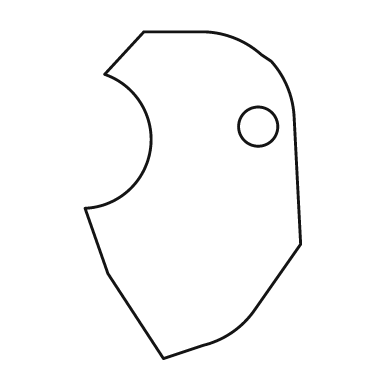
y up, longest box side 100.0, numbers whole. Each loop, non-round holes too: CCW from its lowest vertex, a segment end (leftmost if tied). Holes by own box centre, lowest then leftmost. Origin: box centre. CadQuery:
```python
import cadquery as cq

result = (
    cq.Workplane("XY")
    .moveTo(-9.0, -50.0)
    .lineTo(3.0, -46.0)
    .threePointArc((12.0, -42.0), (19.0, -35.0))
    .lineTo(33.0, -15.0)
    .lineTo(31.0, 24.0)
    .threePointArc((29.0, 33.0), (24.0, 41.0))
    .lineTo(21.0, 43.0)
    .threePointArc((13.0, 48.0), (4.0, 50.0))
    .lineTo(-15.0, 50.0)
    .lineTo(-27.0, 37.0)
    .threePointArc((-13.0, 14.0), (-33.0, -4.0))
    .lineTo(-26.0, -24.0)
    .close()
    .moveTo(20.0, 21.0)
    .circle(6.0)
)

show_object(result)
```